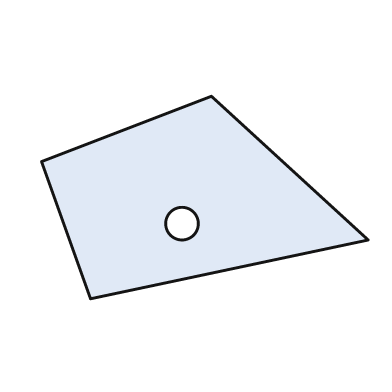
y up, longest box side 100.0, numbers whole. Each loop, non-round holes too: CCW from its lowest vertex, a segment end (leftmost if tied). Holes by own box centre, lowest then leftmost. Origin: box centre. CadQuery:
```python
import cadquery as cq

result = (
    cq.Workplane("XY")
    .moveTo(-35.0, -31.0)
    .lineTo(50.0, -13.0)
    .lineTo(2.0, 31.0)
    .lineTo(-50.0, 11.0)
    .close()
    .moveTo(-7.0, -8.0)
    .circle(5.0)
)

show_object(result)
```